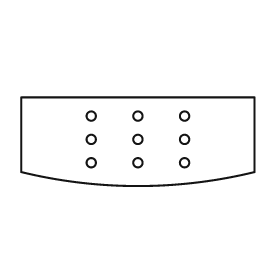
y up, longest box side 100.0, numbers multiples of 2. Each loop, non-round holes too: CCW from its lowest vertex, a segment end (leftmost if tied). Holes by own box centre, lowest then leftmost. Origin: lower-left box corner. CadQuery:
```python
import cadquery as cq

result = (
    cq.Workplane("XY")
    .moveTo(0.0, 6.0)
    .threePointArc((50.0, 0.0), (100.0, 6.0))
    .lineTo(100.0, 38.0)
    .lineTo(0.0, 38.0)
    .close()
    .moveTo(30.0, 10.0)
    .circle(2.0)
    .moveTo(50.0, 10.0)
    .circle(2.0)
    .moveTo(70.0, 10.0)
    .circle(2.0)
    .moveTo(30.0, 20.0)
    .circle(2.0)
    .moveTo(50.0, 20.0)
    .circle(2.0)
    .moveTo(70.0, 20.0)
    .circle(2.0)
    .moveTo(30.0, 30.0)
    .circle(2.0)
    .moveTo(50.0, 30.0)
    .circle(2.0)
    .moveTo(70.0, 30.0)
    .circle(2.0)
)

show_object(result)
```